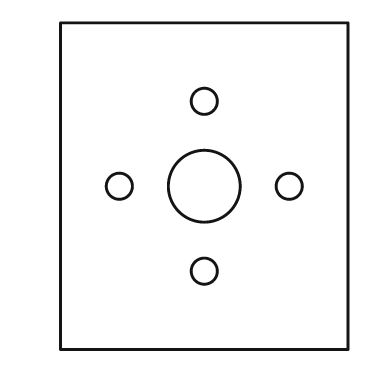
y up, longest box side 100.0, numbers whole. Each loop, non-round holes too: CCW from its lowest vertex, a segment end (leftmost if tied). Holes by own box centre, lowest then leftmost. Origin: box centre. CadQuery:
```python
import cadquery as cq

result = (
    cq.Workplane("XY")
    .moveTo(-44.0, -50.0)
    .lineTo(44.0, -50.0)
    .lineTo(44.0, 50.0)
    .lineTo(-44.0, 50.0)
    .close()
    .moveTo(0.0, -26.0)
    .circle(4.0)
    .moveTo(-26.0, 0.0)
    .circle(4.0)
    .moveTo(0.0, 0.0)
    .circle(11.0)
    .moveTo(26.0, 0.0)
    .circle(4.0)
    .moveTo(0.0, 26.0)
    .circle(4.0)
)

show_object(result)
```